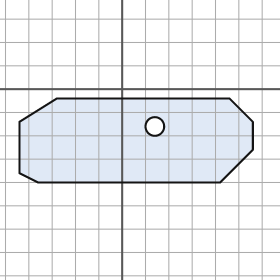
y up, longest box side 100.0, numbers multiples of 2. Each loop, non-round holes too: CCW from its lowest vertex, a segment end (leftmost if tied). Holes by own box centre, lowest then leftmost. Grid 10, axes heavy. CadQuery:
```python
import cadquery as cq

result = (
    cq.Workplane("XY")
    .moveTo(-36.0, -40.0)
    .lineTo(42.0, -40.0)
    .lineTo(56.0, -26.0)
    .lineTo(56.0, -14.0)
    .lineTo(46.0, -4.0)
    .lineTo(-28.0, -4.0)
    .lineTo(-44.0, -14.0)
    .lineTo(-44.0, -36.0)
    .close()
    .moveTo(14.0, -16.0)
    .circle(4.0)
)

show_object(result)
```